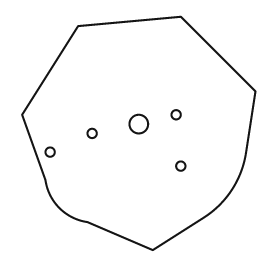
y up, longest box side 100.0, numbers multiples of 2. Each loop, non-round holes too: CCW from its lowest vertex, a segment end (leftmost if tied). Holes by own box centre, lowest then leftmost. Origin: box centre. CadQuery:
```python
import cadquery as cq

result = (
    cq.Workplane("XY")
    .moveTo(6.0, -50.0)
    .lineTo(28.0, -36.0)
    .threePointArc((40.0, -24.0), (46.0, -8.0))
    .lineTo(50.0, 18.0)
    .lineTo(18.0, 50.0)
    .lineTo(-26.0, 46.0)
    .lineTo(-50.0, 8.0)
    .lineTo(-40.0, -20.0)
    .threePointArc((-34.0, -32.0), (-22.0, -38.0))
    .close()
    .moveTo(18.0, -14.0)
    .circle(2.0)
    .moveTo(-38.0, -8.0)
    .circle(2.0)
    .moveTo(-20.0, 0.0)
    .circle(2.0)
    .moveTo(0.0, 4.0)
    .circle(4.0)
    .moveTo(16.0, 8.0)
    .circle(2.0)
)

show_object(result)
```